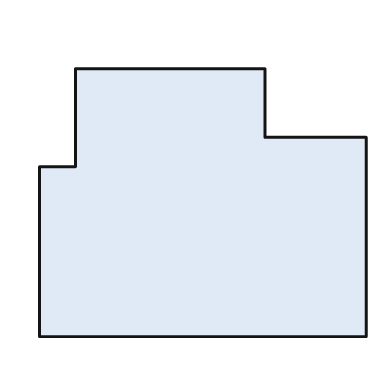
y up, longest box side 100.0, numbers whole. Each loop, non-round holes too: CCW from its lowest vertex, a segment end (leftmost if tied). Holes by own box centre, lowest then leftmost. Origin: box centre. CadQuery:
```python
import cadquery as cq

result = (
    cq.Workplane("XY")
    .moveTo(-50.0, -41.0)
    .lineTo(50.0, -41.0)
    .lineTo(50.0, 20.0)
    .lineTo(19.0, 20.0)
    .lineTo(19.0, 41.0)
    .lineTo(-39.0, 41.0)
    .lineTo(-39.0, 11.0)
    .lineTo(-50.0, 11.0)
    .close()
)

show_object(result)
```